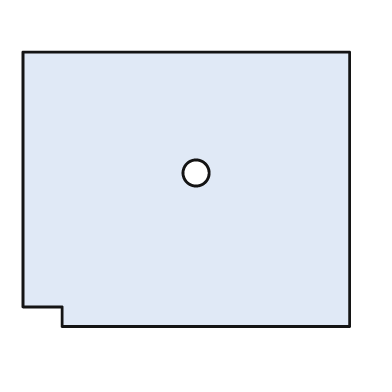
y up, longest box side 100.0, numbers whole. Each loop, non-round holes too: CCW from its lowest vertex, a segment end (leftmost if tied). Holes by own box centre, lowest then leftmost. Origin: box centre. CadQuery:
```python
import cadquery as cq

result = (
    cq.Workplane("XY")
    .moveTo(-38.0, -42.0)
    .lineTo(50.0, -42.0)
    .lineTo(50.0, 42.0)
    .lineTo(-50.0, 42.0)
    .lineTo(-50.0, -36.0)
    .lineTo(-38.0, -36.0)
    .close()
    .moveTo(3.0, 5.0)
    .circle(4.0)
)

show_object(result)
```